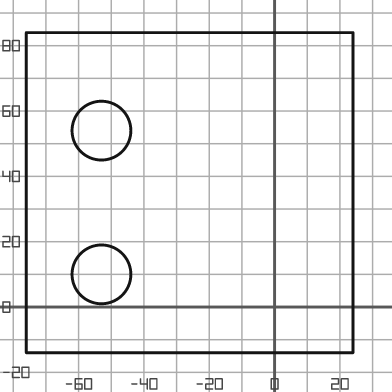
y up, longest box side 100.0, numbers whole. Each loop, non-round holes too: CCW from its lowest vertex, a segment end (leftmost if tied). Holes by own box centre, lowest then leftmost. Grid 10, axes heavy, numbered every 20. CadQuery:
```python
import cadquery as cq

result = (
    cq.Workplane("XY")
    .moveTo(-76.0, -14.0)
    .lineTo(24.0, -14.0)
    .lineTo(24.0, 84.0)
    .lineTo(-76.0, 84.0)
    .close()
    .moveTo(-53.0, 10.0)
    .circle(9.0)
    .moveTo(-53.0, 54.0)
    .circle(9.0)
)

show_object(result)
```